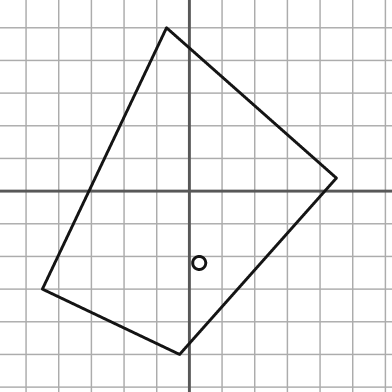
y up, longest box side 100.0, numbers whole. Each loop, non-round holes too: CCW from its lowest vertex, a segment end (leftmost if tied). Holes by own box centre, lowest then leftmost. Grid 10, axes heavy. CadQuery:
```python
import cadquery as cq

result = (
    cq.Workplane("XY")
    .moveTo(-3.0, -50.0)
    .lineTo(45.0, 4.0)
    .lineTo(-7.0, 50.0)
    .lineTo(-45.0, -30.0)
    .close()
    .moveTo(3.0, -22.0)
    .circle(2.0)
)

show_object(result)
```